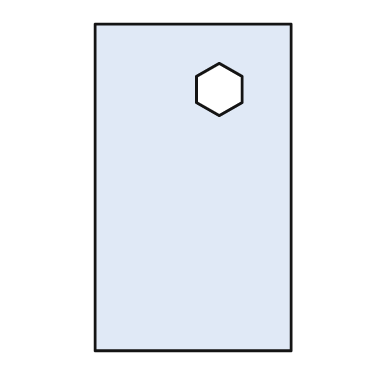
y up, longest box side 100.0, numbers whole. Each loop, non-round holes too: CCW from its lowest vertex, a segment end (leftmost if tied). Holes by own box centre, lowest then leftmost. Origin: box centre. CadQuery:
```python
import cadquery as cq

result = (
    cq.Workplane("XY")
    .moveTo(-30.0, -50.0)
    .lineTo(30.0, -50.0)
    .lineTo(30.0, 50.0)
    .lineTo(-30.0, 50.0)
    .close()
    .moveTo(8.0, 22.0)
    .lineTo(15.0, 26.0)
    .lineTo(15.0, 34.0)
    .lineTo(8.0, 38.0)
    .lineTo(1.0, 34.0)
    .lineTo(1.0, 26.0)
    .close()
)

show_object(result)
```